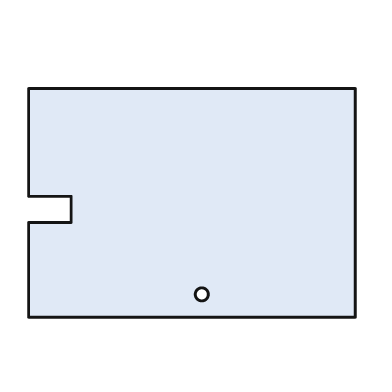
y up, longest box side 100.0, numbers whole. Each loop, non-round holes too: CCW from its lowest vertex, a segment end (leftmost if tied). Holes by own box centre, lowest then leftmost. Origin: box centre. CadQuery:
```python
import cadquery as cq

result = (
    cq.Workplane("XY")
    .moveTo(-50.0, -35.0)
    .lineTo(50.0, -35.0)
    .lineTo(50.0, 35.0)
    .lineTo(-50.0, 35.0)
    .lineTo(-50.0, 2.0)
    .lineTo(-37.0, 2.0)
    .lineTo(-37.0, -6.0)
    .lineTo(-50.0, -6.0)
    .close()
    .moveTo(3.0, -28.0)
    .circle(2.0)
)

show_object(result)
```